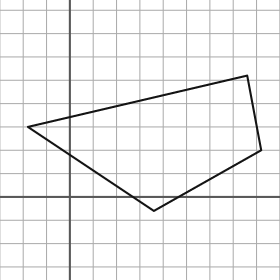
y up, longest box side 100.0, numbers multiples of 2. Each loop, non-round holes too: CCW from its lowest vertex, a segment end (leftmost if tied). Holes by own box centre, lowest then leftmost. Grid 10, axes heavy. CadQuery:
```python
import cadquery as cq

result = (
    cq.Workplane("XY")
    .moveTo(36.0, -6.0)
    .lineTo(82.0, 20.0)
    .lineTo(76.0, 52.0)
    .lineTo(-18.0, 30.0)
    .close()
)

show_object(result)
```